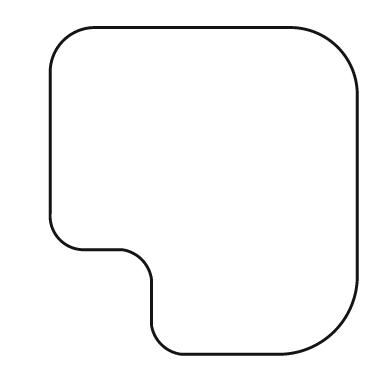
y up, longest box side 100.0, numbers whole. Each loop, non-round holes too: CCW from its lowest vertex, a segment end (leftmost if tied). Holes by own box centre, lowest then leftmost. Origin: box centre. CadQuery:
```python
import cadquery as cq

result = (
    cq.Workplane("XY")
    .moveTo(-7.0, -50.0)
    .lineTo(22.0, -50.0)
    .threePointArc((40.0, -43.0), (47.0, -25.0))
    .lineTo(47.0, 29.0)
    .threePointArc((41.0, 44.0), (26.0, 50.0))
    .lineTo(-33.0, 50.0)
    .threePointArc((-43.0, 46.0), (-47.0, 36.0))
    .lineTo(-47.0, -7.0)
    .threePointArc((-44.0, -15.0), (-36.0, -18.0))
    .lineTo(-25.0, -18.0)
    .threePointArc((-19.0, -21.0), (-16.0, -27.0))
    .lineTo(-16.0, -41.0)
    .threePointArc((-13.0, -47.0), (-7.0, -50.0))
    .close()
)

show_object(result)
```